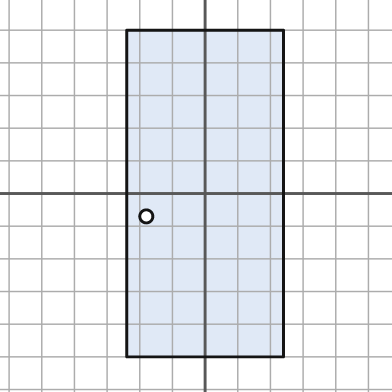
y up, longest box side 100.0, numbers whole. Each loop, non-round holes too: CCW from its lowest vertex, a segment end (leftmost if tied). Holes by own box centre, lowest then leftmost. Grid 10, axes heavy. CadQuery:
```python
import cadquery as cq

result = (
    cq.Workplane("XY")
    .moveTo(-24.0, -50.0)
    .lineTo(24.0, -50.0)
    .lineTo(24.0, 50.0)
    .lineTo(-24.0, 50.0)
    .close()
    .moveTo(-18.0, -7.0)
    .circle(2.0)
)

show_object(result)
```